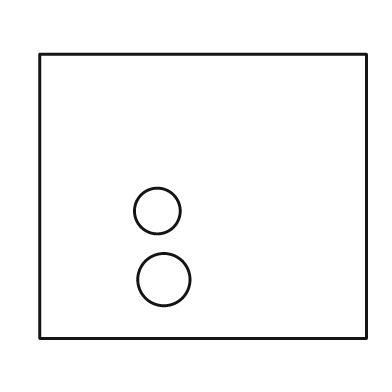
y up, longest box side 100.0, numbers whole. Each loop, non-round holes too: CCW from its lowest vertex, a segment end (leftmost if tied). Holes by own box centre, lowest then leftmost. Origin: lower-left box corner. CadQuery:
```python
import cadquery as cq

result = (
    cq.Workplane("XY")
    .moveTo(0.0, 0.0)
    .lineTo(100.0, 0.0)
    .lineTo(100.0, 87.0)
    .lineTo(0.0, 87.0)
    .close()
    .moveTo(38.0, 18.0)
    .circle(8.0)
    .moveTo(36.0, 39.0)
    .circle(7.0)
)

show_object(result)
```